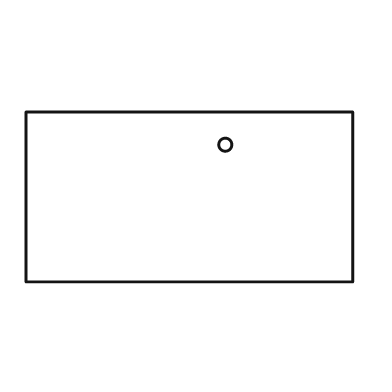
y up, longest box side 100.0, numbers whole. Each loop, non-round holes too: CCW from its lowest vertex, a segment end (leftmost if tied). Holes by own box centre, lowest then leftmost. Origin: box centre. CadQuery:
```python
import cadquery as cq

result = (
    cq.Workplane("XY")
    .moveTo(-50.0, -26.0)
    .lineTo(50.0, -26.0)
    .lineTo(50.0, 26.0)
    .lineTo(-50.0, 26.0)
    .close()
    .moveTo(11.0, 16.0)
    .circle(2.0)
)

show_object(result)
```